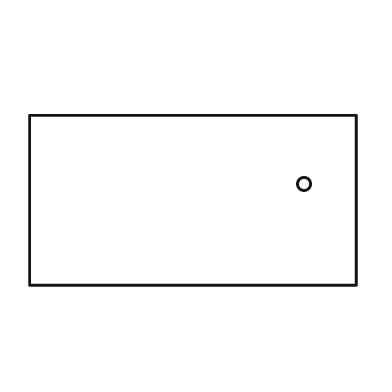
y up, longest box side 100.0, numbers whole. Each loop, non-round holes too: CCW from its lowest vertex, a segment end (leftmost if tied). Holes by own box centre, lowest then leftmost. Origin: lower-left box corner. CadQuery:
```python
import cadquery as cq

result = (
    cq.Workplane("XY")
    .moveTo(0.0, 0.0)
    .lineTo(100.0, 0.0)
    .lineTo(100.0, 52.0)
    .lineTo(0.0, 52.0)
    .close()
    .moveTo(84.0, 31.0)
    .circle(2.0)
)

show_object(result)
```